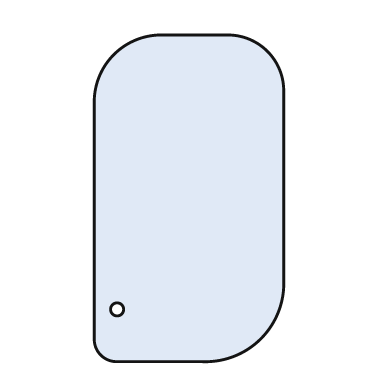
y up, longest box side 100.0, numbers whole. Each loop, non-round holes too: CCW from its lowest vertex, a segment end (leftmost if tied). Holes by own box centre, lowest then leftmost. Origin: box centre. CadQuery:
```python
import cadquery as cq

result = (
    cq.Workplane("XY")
    .moveTo(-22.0, -50.0)
    .lineTo(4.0, -50.0)
    .threePointArc((22.0, -43.0), (29.0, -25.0))
    .lineTo(29.0, 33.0)
    .threePointArc((24.0, 45.0), (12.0, 50.0))
    .lineTo(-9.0, 50.0)
    .threePointArc((-23.0, 44.0), (-29.0, 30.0))
    .lineTo(-29.0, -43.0)
    .threePointArc((-27.0, -48.0), (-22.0, -50.0))
    .close()
    .moveTo(-22.0, -34.0)
    .circle(2.0)
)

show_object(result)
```